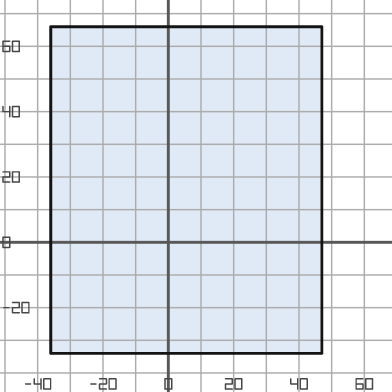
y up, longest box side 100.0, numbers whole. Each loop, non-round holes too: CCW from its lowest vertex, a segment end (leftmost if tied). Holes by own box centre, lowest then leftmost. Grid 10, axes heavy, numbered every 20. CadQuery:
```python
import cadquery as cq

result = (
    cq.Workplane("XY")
    .moveTo(-36.0, -34.0)
    .lineTo(47.0, -34.0)
    .lineTo(47.0, 66.0)
    .lineTo(-36.0, 66.0)
    .close()
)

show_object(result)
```